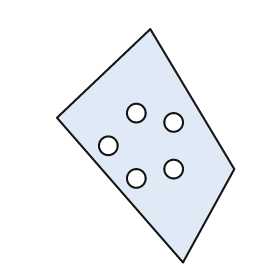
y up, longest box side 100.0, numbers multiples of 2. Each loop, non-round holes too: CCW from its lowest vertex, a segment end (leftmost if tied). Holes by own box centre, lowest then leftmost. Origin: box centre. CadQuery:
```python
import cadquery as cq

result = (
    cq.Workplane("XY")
    .moveTo(16.0, -50.0)
    .lineTo(38.0, -10.0)
    .lineTo(2.0, 50.0)
    .lineTo(-38.0, 12.0)
    .close()
    .moveTo(-4.0, -14.0)
    .circle(4.0)
    .moveTo(12.0, -10.0)
    .circle(4.0)
    .moveTo(-16.0, 0.0)
    .circle(4.0)
    .moveTo(12.0, 10.0)
    .circle(4.0)
    .moveTo(-4.0, 14.0)
    .circle(4.0)
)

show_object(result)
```